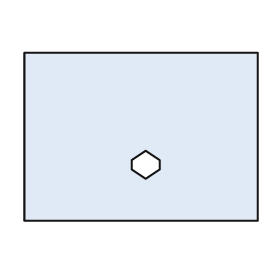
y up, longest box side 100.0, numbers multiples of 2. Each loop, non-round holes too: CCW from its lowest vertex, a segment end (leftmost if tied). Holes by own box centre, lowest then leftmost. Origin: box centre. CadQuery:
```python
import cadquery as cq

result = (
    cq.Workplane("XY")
    .moveTo(-50.0, -36.0)
    .lineTo(50.0, -36.0)
    .lineTo(50.0, 36.0)
    .lineTo(-50.0, 36.0)
    .close()
    .moveTo(2.0, -18.0)
    .lineTo(8.0, -14.0)
    .lineTo(8.0, -10.0)
    .lineTo(2.0, -6.0)
    .lineTo(-4.0, -10.0)
    .lineTo(-4.0, -14.0)
    .close()
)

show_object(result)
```